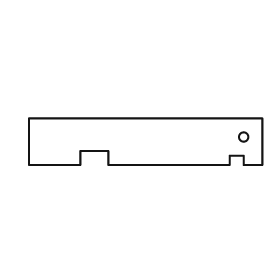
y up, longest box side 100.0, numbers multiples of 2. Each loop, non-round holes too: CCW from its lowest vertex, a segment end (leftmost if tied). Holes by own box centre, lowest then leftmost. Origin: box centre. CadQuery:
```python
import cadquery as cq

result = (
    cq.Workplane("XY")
    .moveTo(-50.0, -10.0)
    .lineTo(-28.0, -10.0)
    .lineTo(-28.0, -4.0)
    .lineTo(-16.0, -4.0)
    .lineTo(-16.0, -10.0)
    .lineTo(36.0, -10.0)
    .lineTo(36.0, -6.0)
    .lineTo(42.0, -6.0)
    .lineTo(42.0, -10.0)
    .lineTo(50.0, -10.0)
    .lineTo(50.0, 10.0)
    .lineTo(-50.0, 10.0)
    .close()
    .moveTo(42.0, 2.0)
    .circle(2.0)
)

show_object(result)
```